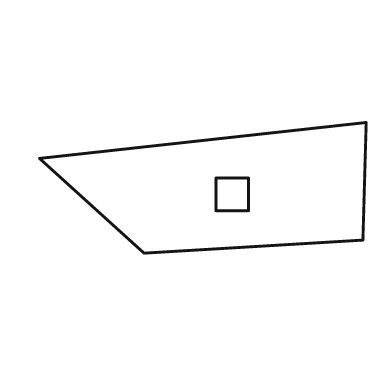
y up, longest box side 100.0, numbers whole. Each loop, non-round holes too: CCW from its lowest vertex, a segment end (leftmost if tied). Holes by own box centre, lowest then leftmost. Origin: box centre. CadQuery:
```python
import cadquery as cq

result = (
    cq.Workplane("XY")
    .moveTo(-18.0, -20.0)
    .lineTo(49.0, -16.0)
    .lineTo(50.0, 20.0)
    .lineTo(-50.0, 9.0)
    .close()
    .moveTo(4.0, -7.0)
    .lineTo(14.0, -7.0)
    .lineTo(14.0, 3.0)
    .lineTo(4.0, 3.0)
    .close()
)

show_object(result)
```